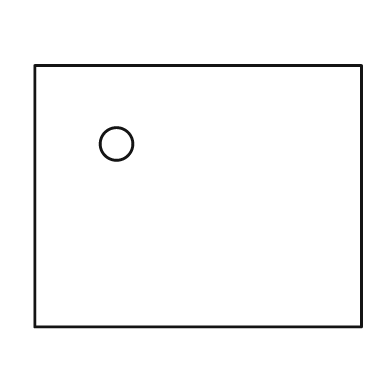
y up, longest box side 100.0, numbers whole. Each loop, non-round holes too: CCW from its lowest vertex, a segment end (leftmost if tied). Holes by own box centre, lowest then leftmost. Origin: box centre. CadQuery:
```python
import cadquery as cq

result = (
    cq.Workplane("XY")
    .moveTo(-50.0, -40.0)
    .lineTo(50.0, -40.0)
    .lineTo(50.0, 40.0)
    .lineTo(-50.0, 40.0)
    .close()
    .moveTo(-25.0, 16.0)
    .circle(5.0)
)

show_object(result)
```